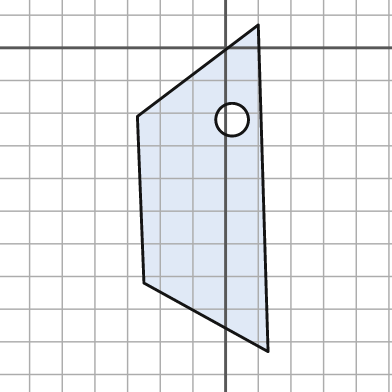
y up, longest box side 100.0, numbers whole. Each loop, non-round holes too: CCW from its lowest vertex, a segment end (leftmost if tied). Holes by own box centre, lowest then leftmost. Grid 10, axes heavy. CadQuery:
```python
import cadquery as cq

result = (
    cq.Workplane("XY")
    .moveTo(13.0, -93.0)
    .lineTo(10.0, 7.0)
    .lineTo(-27.0, -21.0)
    .lineTo(-25.0, -72.0)
    .close()
    .moveTo(2.0, -22.0)
    .circle(5.0)
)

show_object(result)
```